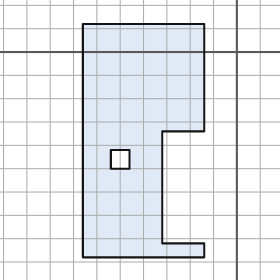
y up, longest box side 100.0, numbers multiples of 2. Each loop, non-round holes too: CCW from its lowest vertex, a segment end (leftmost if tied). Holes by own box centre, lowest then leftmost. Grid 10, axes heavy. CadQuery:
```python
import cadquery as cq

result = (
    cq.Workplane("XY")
    .moveTo(-66.0, -88.0)
    .lineTo(-14.0, -88.0)
    .lineTo(-14.0, -82.0)
    .lineTo(-32.0, -82.0)
    .lineTo(-32.0, -34.0)
    .lineTo(-14.0, -34.0)
    .lineTo(-14.0, 12.0)
    .lineTo(-66.0, 12.0)
    .close()
    .moveTo(-54.0, -50.0)
    .lineTo(-46.0, -50.0)
    .lineTo(-46.0, -42.0)
    .lineTo(-54.0, -42.0)
    .close()
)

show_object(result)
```